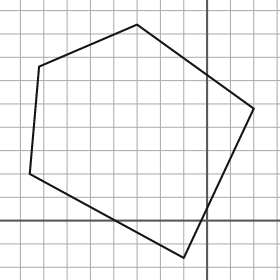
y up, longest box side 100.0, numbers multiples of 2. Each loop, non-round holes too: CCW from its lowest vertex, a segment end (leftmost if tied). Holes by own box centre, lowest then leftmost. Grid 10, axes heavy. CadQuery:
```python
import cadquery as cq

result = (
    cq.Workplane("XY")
    .moveTo(-10.0, -16.0)
    .lineTo(20.0, 48.0)
    .lineTo(-30.0, 84.0)
    .lineTo(-72.0, 66.0)
    .lineTo(-76.0, 20.0)
    .close()
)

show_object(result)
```